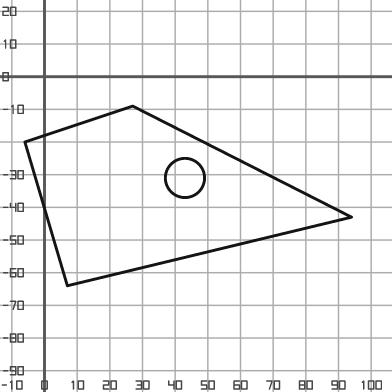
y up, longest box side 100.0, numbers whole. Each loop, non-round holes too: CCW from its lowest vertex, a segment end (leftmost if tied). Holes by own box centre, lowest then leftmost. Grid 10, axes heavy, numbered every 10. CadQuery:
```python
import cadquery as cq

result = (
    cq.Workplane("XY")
    .moveTo(7.0, -64.0)
    .lineTo(94.0, -43.0)
    .lineTo(27.0, -9.0)
    .lineTo(-6.0, -20.0)
    .close()
    .moveTo(43.0, -31.0)
    .circle(6.0)
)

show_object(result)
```